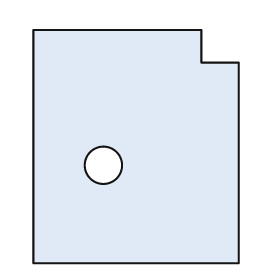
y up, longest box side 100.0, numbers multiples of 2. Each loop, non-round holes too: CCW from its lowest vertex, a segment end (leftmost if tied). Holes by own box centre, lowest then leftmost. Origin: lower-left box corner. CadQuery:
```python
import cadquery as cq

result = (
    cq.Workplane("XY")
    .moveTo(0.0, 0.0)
    .lineTo(88.0, 0.0)
    .lineTo(88.0, 86.0)
    .lineTo(72.0, 86.0)
    .lineTo(72.0, 100.0)
    .lineTo(0.0, 100.0)
    .close()
    .moveTo(30.0, 42.0)
    .circle(8.0)
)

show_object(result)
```